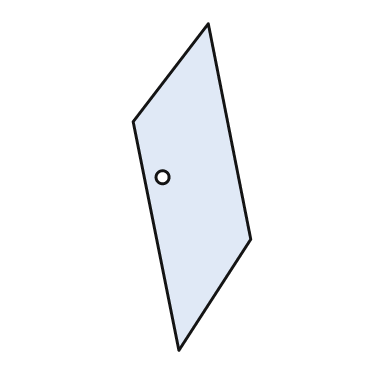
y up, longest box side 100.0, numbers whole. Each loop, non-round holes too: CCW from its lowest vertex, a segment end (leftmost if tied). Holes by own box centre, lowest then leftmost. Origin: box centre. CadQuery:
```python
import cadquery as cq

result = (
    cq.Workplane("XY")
    .moveTo(-4.0, -50.0)
    .lineTo(18.0, -16.0)
    .lineTo(5.0, 50.0)
    .lineTo(-18.0, 20.0)
    .close()
    .moveTo(-9.0, 3.0)
    .circle(2.0)
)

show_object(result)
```